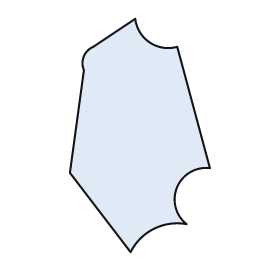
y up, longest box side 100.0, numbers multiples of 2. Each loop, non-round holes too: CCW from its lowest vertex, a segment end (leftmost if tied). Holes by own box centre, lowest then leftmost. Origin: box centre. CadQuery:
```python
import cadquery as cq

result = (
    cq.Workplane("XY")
    .moveTo(-4.0, -50.0)
    .threePointArc((6.0, -40.0), (20.0, -38.0))
    .threePointArc((16.0, -22.0), (30.0, -14.0))
    .lineTo(16.0, 38.0)
    .threePointArc((4.0, 40.0), (-2.0, 50.0))
    .lineTo(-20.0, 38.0)
    .threePointArc((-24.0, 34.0), (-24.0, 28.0))
    .lineTo(-30.0, -16.0)
    .close()
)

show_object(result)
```